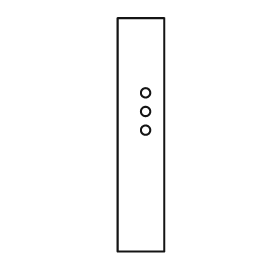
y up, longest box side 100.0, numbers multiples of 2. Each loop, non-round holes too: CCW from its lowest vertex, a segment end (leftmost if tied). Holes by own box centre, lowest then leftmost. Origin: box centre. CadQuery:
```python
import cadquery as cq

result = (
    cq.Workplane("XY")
    .moveTo(-10.0, -50.0)
    .lineTo(10.0, -50.0)
    .lineTo(10.0, 50.0)
    .lineTo(-10.0, 50.0)
    .close()
    .moveTo(2.0, 2.0)
    .circle(2.0)
    .moveTo(2.0, 10.0)
    .circle(2.0)
    .moveTo(2.0, 18.0)
    .circle(2.0)
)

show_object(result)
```